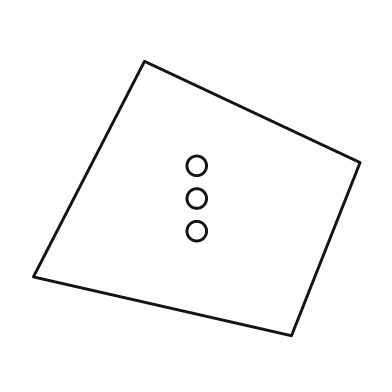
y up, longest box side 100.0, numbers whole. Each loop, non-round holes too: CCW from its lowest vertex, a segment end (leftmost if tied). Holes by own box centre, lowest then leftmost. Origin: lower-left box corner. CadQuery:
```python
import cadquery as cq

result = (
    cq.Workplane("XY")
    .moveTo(79.0, 0.0)
    .lineTo(100.0, 53.0)
    .lineTo(34.0, 84.0)
    .lineTo(0.0, 18.0)
    .close()
    .moveTo(50.0, 32.0)
    .circle(3.0)
    .moveTo(50.0, 42.0)
    .circle(3.0)
    .moveTo(50.0, 52.0)
    .circle(3.0)
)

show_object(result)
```